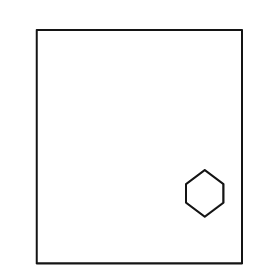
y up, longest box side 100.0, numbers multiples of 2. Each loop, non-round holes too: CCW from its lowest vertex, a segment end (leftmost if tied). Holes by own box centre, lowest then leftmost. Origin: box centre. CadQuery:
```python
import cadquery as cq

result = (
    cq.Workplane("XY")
    .moveTo(-44.0, -50.0)
    .lineTo(44.0, -50.0)
    .lineTo(44.0, 50.0)
    .lineTo(-44.0, 50.0)
    .close()
    .moveTo(28.0, -30.0)
    .lineTo(36.0, -24.0)
    .lineTo(36.0, -16.0)
    .lineTo(28.0, -10.0)
    .lineTo(20.0, -16.0)
    .lineTo(20.0, -24.0)
    .close()
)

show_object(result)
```